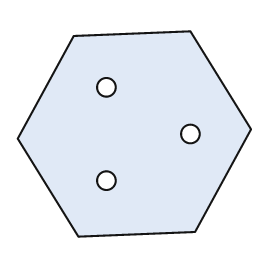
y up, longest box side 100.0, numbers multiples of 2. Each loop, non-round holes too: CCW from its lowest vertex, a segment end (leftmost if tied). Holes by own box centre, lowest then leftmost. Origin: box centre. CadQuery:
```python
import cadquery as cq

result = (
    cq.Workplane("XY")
    .moveTo(-24.0, -44.0)
    .lineTo(26.0, -42.0)
    .lineTo(50.0, 2.0)
    .lineTo(24.0, 44.0)
    .lineTo(-26.0, 42.0)
    .lineTo(-50.0, -2.0)
    .close()
    .moveTo(-12.0, -20.0)
    .circle(4.0)
    .moveTo(24.0, 0.0)
    .circle(4.0)
    .moveTo(-12.0, 20.0)
    .circle(4.0)
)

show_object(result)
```